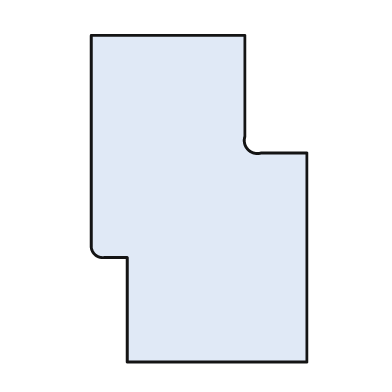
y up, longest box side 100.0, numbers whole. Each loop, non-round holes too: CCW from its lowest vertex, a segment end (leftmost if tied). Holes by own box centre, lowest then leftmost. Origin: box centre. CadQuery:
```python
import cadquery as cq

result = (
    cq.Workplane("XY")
    .moveTo(-22.0, -50.0)
    .lineTo(33.0, -50.0)
    .lineTo(33.0, 14.0)
    .lineTo(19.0, 14.0)
    .threePointArc((15.0, 15.0), (14.0, 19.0))
    .lineTo(14.0, 50.0)
    .lineTo(-33.0, 50.0)
    .lineTo(-33.0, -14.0)
    .threePointArc((-32.0, -17.0), (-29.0, -18.0))
    .lineTo(-22.0, -18.0)
    .close()
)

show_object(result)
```